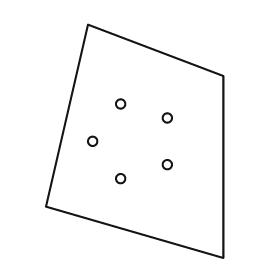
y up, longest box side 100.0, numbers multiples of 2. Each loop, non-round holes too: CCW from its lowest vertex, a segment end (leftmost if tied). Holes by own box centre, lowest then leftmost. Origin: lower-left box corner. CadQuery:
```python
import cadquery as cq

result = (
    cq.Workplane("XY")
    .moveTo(76.0, 0.0)
    .lineTo(76.0, 78.0)
    .lineTo(18.0, 100.0)
    .lineTo(0.0, 22.0)
    .close()
    .moveTo(32.0, 34.0)
    .circle(2.0)
    .moveTo(52.0, 40.0)
    .circle(2.0)
    .moveTo(20.0, 50.0)
    .circle(2.0)
    .moveTo(52.0, 60.0)
    .circle(2.0)
    .moveTo(32.0, 66.0)
    .circle(2.0)
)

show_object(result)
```